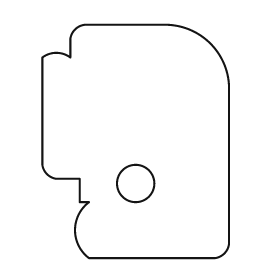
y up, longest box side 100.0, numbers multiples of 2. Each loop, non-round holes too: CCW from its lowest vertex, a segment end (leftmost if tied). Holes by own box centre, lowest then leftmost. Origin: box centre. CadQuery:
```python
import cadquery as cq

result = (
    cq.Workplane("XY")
    .moveTo(-20.0, -50.0)
    .lineTo(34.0, -50.0)
    .threePointArc((38.0, -48.0), (40.0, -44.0))
    .lineTo(40.0, 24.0)
    .threePointArc((32.0, 42.0), (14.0, 50.0))
    .lineTo(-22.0, 50.0)
    .threePointArc((-26.0, 48.0), (-28.0, 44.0))
    .lineTo(-28.0, 36.0)
    .threePointArc((-34.0, 38.0), (-40.0, 36.0))
    .lineTo(-40.0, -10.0)
    .threePointArc((-38.0, -14.0), (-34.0, -16.0))
    .lineTo(-24.0, -16.0)
    .lineTo(-24.0, -26.0)
    .lineTo(-20.0, -26.0)
    .threePointArc((-26.0, -38.0), (-20.0, -50.0))
    .close()
    .moveTo(0.0, -18.0)
    .circle(8.0)
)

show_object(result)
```